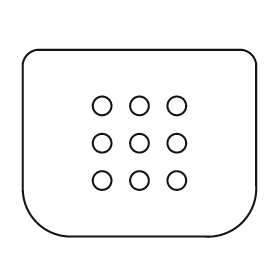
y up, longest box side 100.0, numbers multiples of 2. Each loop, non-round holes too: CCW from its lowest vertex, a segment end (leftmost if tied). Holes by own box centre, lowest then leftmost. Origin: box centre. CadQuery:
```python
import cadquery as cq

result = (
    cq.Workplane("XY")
    .moveTo(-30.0, -40.0)
    .lineTo(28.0, -40.0)
    .threePointArc((44.0, -34.0), (50.0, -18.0))
    .lineTo(50.0, 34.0)
    .threePointArc((48.0, 38.0), (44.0, 40.0))
    .lineTo(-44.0, 40.0)
    .threePointArc((-48.0, 38.0), (-50.0, 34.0))
    .lineTo(-50.0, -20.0)
    .threePointArc((-44.0, -34.0), (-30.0, -40.0))
    .close()
    .moveTo(-16.0, -16.0)
    .circle(4.0)
    .moveTo(0.0, -16.0)
    .circle(4.0)
    .moveTo(16.0, -16.0)
    .circle(4.0)
    .moveTo(-16.0, 0.0)
    .circle(4.0)
    .moveTo(0.0, 0.0)
    .circle(4.0)
    .moveTo(16.0, 0.0)
    .circle(4.0)
    .moveTo(-16.0, 16.0)
    .circle(4.0)
    .moveTo(0.0, 16.0)
    .circle(4.0)
    .moveTo(16.0, 16.0)
    .circle(4.0)
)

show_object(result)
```